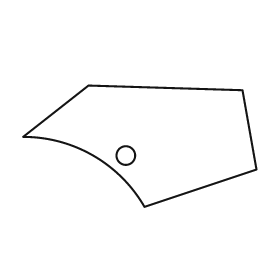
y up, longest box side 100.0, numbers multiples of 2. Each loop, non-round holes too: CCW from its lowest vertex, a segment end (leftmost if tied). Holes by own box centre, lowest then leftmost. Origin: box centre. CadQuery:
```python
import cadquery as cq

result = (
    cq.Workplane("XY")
    .moveTo(2.0, -26.0)
    .lineTo(50.0, -10.0)
    .lineTo(44.0, 24.0)
    .lineTo(-22.0, 26.0)
    .lineTo(-50.0, 4.0)
    .threePointArc((-20.0, -4.0), (2.0, -26.0))
    .close()
    .moveTo(-6.0, -4.0)
    .circle(4.0)
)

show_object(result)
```